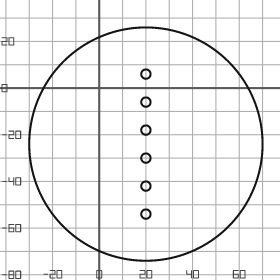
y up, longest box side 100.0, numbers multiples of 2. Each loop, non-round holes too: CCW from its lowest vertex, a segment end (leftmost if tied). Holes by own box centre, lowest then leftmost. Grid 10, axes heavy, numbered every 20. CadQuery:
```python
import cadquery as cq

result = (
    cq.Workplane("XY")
    .moveTo(20.0, -24.0)
    .circle(50.0)
    .moveTo(20.0, -54.0)
    .circle(2.0)
    .moveTo(20.0, -42.0)
    .circle(2.0)
    .moveTo(20.0, -30.0)
    .circle(2.0)
    .moveTo(20.0, -18.0)
    .circle(2.0)
    .moveTo(20.0, -6.0)
    .circle(2.0)
    .moveTo(20.0, 6.0)
    .circle(2.0)
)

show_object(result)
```